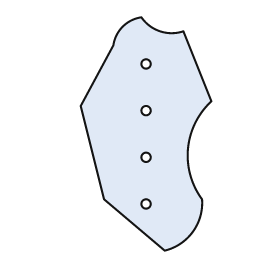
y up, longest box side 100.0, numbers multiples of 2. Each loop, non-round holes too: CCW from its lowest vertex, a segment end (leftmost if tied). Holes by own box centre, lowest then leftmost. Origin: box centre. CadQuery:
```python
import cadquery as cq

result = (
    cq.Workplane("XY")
    .moveTo(8.0, -50.0)
    .threePointArc((20.0, -42.0), (24.0, -28.0))
    .threePointArc((18.0, -6.0), (28.0, 14.0))
    .lineTo(16.0, 44.0)
    .threePointArc((6.0, 44.0), (-2.0, 50.0))
    .threePointArc((-10.0, 46.0), (-14.0, 38.0))
    .lineTo(-28.0, 12.0)
    .lineTo(-18.0, -28.0)
    .close()
    .moveTo(0.0, -30.0)
    .circle(2.0)
    .moveTo(0.0, -10.0)
    .circle(2.0)
    .moveTo(0.0, 10.0)
    .circle(2.0)
    .moveTo(0.0, 30.0)
    .circle(2.0)
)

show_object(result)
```